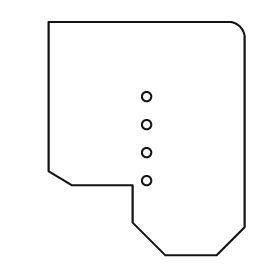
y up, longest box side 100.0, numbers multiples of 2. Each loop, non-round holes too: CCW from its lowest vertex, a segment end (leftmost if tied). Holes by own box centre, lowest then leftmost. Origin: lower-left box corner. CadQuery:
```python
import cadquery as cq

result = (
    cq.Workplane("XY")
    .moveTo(50.0, 0.0)
    .lineTo(72.0, 0.0)
    .lineTo(84.0, 12.0)
    .lineTo(84.0, 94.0)
    .threePointArc((82.0, 98.0), (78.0, 100.0))
    .lineTo(0.0, 100.0)
    .lineTo(0.0, 36.0)
    .lineTo(10.0, 30.0)
    .lineTo(36.0, 30.0)
    .lineTo(36.0, 14.0)
    .close()
    .moveTo(42.0, 32.0)
    .circle(2.0)
    .moveTo(42.0, 44.0)
    .circle(2.0)
    .moveTo(42.0, 56.0)
    .circle(2.0)
    .moveTo(42.0, 68.0)
    .circle(2.0)
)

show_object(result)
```